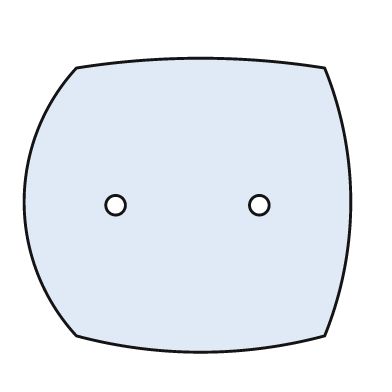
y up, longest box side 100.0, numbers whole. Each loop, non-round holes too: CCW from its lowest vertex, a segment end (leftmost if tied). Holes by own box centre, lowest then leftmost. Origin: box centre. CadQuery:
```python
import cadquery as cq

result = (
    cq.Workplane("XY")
    .moveTo(-34.0, -40.0)
    .threePointArc((4.0, -45.0), (42.0, -40.0))
    .threePointArc((50.0, 1.0), (42.0, 42.0))
    .threePointArc((4.0, 45.0), (-34.0, 42.0))
    .threePointArc((-50.0, 1.0), (-34.0, -40.0))
    .close()
    .moveTo(-22.0, 0.0)
    .circle(3.0)
    .moveTo(22.0, 0.0)
    .circle(3.0)
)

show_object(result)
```